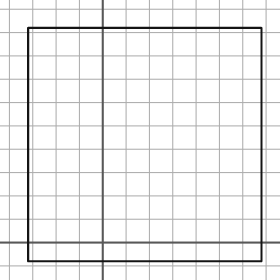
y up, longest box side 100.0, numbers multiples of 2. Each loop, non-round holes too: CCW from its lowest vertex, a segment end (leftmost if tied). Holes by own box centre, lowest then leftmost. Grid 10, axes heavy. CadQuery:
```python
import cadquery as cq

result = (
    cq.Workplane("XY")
    .moveTo(-32.0, -8.0)
    .lineTo(68.0, -8.0)
    .lineTo(68.0, 92.0)
    .lineTo(-32.0, 92.0)
    .close()
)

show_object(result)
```